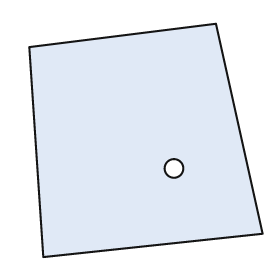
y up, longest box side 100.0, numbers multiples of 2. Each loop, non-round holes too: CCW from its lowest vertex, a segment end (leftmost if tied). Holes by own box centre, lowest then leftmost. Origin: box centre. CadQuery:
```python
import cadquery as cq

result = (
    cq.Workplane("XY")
    .moveTo(-44.0, -50.0)
    .lineTo(50.0, -40.0)
    .lineTo(30.0, 50.0)
    .lineTo(-50.0, 40.0)
    .close()
    .moveTo(12.0, -12.0)
    .circle(4.0)
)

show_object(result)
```